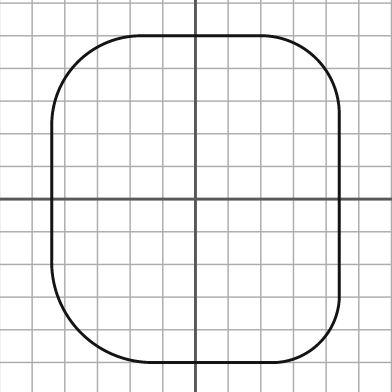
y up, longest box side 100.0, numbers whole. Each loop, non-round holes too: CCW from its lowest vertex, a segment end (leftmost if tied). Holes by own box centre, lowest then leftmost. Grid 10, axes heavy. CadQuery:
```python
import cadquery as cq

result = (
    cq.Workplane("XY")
    .moveTo(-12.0, -50.0)
    .lineTo(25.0, -50.0)
    .threePointArc((38.0, -44.0), (44.0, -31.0))
    .lineTo(44.0, 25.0)
    .threePointArc((37.0, 43.0), (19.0, 50.0))
    .lineTo(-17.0, 50.0)
    .threePointArc((-36.0, 42.0), (-44.0, 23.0))
    .lineTo(-44.0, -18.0)
    .threePointArc((-35.0, -41.0), (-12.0, -50.0))
    .close()
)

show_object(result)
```